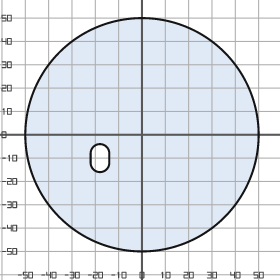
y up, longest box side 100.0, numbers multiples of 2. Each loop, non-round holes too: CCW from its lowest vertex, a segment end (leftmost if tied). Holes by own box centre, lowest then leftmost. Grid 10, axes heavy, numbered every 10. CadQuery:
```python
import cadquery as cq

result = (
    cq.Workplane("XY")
    .moveTo(0.0, 0.0)
    .circle(50.0)
    .moveTo(-22.0, -12.0)
    .threePointArc((-18.0, -16.0), (-14.0, -12.0))
    .lineTo(-14.0, -8.0)
    .threePointArc((-18.0, -4.0), (-22.0, -8.0))
    .close()
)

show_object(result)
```